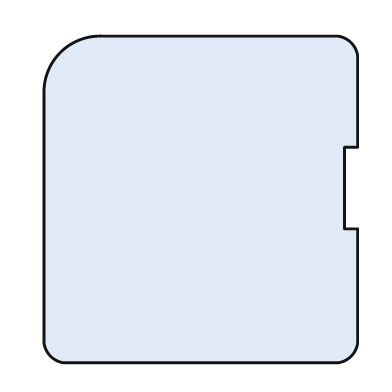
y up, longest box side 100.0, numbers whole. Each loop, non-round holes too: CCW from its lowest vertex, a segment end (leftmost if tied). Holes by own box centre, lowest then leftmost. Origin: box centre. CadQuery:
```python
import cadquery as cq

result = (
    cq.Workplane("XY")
    .moveTo(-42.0, -50.0)
    .lineTo(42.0, -50.0)
    .threePointArc((46.0, -48.0), (48.0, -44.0))
    .lineTo(48.0, -9.0)
    .lineTo(44.0, -9.0)
    .lineTo(44.0, 16.0)
    .lineTo(48.0, 16.0)
    .lineTo(48.0, 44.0)
    .threePointArc((46.0, 48.0), (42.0, 50.0))
    .lineTo(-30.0, 50.0)
    .threePointArc((-43.0, 45.0), (-48.0, 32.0))
    .lineTo(-48.0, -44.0)
    .threePointArc((-46.0, -48.0), (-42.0, -50.0))
    .close()
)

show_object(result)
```